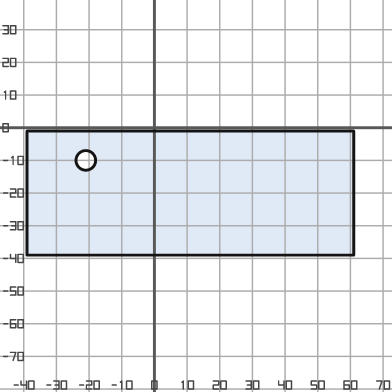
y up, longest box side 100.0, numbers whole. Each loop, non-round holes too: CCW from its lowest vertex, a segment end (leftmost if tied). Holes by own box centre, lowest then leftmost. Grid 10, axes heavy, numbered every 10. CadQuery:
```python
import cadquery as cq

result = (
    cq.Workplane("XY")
    .moveTo(-39.0, -39.0)
    .lineTo(61.0, -39.0)
    .lineTo(61.0, -1.0)
    .lineTo(-39.0, -1.0)
    .close()
    .moveTo(-21.0, -10.0)
    .circle(3.0)
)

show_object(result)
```